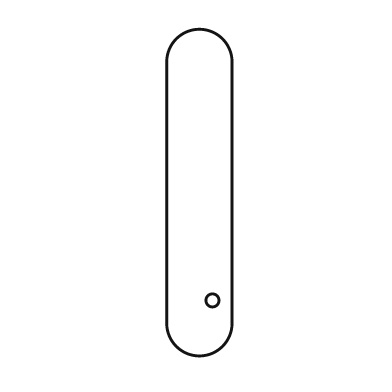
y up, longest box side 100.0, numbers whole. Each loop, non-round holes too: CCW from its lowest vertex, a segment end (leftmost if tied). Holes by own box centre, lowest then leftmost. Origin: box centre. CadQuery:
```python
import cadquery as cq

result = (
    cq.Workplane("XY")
    .moveTo(-10.0, -40.0)
    .threePointArc((0.0, -50.0), (10.0, -40.0))
    .lineTo(10.0, 40.0)
    .threePointArc((0.0, 50.0), (-10.0, 40.0))
    .close()
    .moveTo(4.0, -33.0)
    .circle(2.0)
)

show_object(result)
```